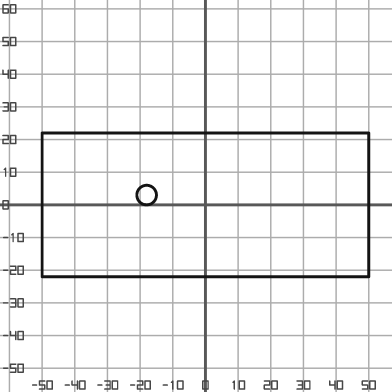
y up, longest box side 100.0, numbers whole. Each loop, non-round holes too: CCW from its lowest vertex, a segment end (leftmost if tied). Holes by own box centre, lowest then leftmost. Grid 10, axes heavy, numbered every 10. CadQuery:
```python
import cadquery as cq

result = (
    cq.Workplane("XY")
    .moveTo(-50.0, -22.0)
    .lineTo(50.0, -22.0)
    .lineTo(50.0, 22.0)
    .lineTo(-50.0, 22.0)
    .close()
    .moveTo(-18.0, 3.0)
    .circle(3.0)
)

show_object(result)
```